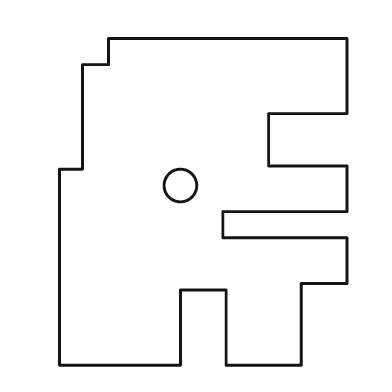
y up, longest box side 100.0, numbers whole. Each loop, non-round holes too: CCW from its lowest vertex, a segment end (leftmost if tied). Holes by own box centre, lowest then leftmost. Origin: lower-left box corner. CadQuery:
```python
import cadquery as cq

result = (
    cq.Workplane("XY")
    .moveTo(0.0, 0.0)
    .lineTo(37.0, 0.0)
    .lineTo(37.0, 23.0)
    .lineTo(51.0, 23.0)
    .lineTo(51.0, 0.0)
    .lineTo(74.0, 0.0)
    .lineTo(74.0, 25.0)
    .lineTo(88.0, 25.0)
    .lineTo(88.0, 39.0)
    .lineTo(50.0, 39.0)
    .lineTo(50.0, 47.0)
    .lineTo(88.0, 47.0)
    .lineTo(88.0, 61.0)
    .lineTo(64.0, 61.0)
    .lineTo(64.0, 77.0)
    .lineTo(88.0, 77.0)
    .lineTo(88.0, 100.0)
    .lineTo(15.0, 100.0)
    .lineTo(15.0, 92.0)
    .lineTo(7.0, 92.0)
    .lineTo(7.0, 60.0)
    .lineTo(0.0, 60.0)
    .close()
    .moveTo(37.0, 55.0)
    .circle(5.0)
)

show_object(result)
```